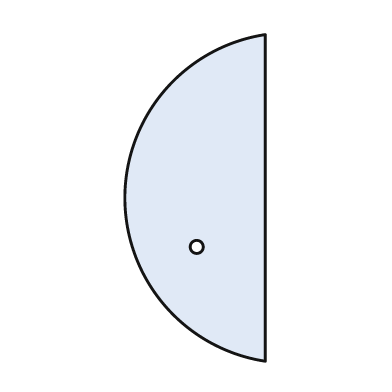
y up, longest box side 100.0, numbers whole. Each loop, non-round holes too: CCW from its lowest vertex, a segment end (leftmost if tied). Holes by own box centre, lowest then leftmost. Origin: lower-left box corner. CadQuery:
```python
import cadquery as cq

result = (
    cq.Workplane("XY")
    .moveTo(43.0, 0.0)
    .lineTo(43.0, 100.0)
    .threePointArc((0.0, 50.0), (43.0, 0.0))
    .close()
    .moveTo(22.0, 35.0)
    .circle(2.0)
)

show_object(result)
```